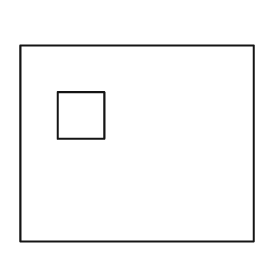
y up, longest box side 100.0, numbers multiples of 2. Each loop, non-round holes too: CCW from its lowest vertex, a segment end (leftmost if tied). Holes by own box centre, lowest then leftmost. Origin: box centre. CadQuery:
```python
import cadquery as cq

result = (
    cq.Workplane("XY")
    .moveTo(-50.0, -42.0)
    .lineTo(50.0, -42.0)
    .lineTo(50.0, 42.0)
    .lineTo(-50.0, 42.0)
    .close()
    .moveTo(-34.0, 2.0)
    .lineTo(-14.0, 2.0)
    .lineTo(-14.0, 22.0)
    .lineTo(-34.0, 22.0)
    .close()
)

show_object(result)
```